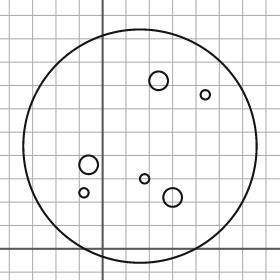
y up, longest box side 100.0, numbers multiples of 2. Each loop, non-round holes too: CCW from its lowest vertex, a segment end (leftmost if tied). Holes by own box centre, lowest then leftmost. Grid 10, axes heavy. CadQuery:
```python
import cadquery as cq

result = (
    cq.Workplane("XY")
    .moveTo(16.0, 44.0)
    .circle(50.0)
    .moveTo(30.0, 22.0)
    .circle(4.0)
    .moveTo(-8.0, 24.0)
    .circle(2.0)
    .moveTo(18.0, 30.0)
    .circle(2.0)
    .moveTo(-6.0, 36.0)
    .circle(4.0)
    .moveTo(44.0, 66.0)
    .circle(2.0)
    .moveTo(24.0, 72.0)
    .circle(4.0)
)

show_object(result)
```